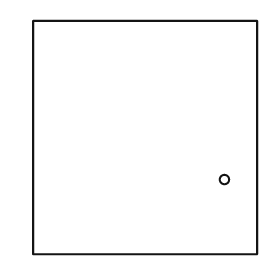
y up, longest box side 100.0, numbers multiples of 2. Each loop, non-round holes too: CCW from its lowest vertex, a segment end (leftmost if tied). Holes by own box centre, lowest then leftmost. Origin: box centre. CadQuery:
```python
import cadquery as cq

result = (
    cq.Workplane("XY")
    .moveTo(-48.0, -50.0)
    .lineTo(48.0, -50.0)
    .lineTo(48.0, 50.0)
    .lineTo(-48.0, 50.0)
    .close()
    .moveTo(34.0, -18.0)
    .circle(2.0)
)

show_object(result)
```